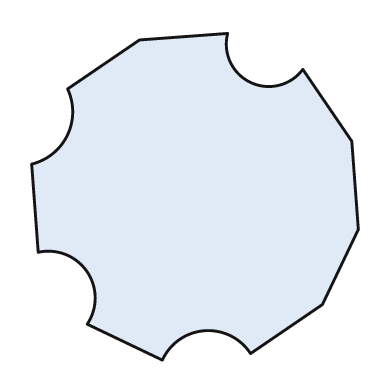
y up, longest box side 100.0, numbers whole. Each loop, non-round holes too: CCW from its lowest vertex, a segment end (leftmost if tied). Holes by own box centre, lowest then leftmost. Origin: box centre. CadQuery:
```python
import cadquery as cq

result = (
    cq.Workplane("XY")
    .moveTo(-10.0, -50.0)
    .threePointArc((3.0, -41.0), (17.0, -48.0))
    .lineTo(39.0, -33.0)
    .lineTo(50.0, -10.0)
    .lineTo(48.0, 17.0)
    .lineTo(33.0, 39.0)
    .threePointArc((17.0, 35.0), (10.0, 50.0))
    .lineTo(-17.0, 48.0)
    .lineTo(-39.0, 33.0)
    .threePointArc((-39.0, 19.0), (-50.0, 10.0))
    .lineTo(-48.0, -17.0)
    .threePointArc((-33.0, -23.0), (-33.0, -39.0))
    .close()
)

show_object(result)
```